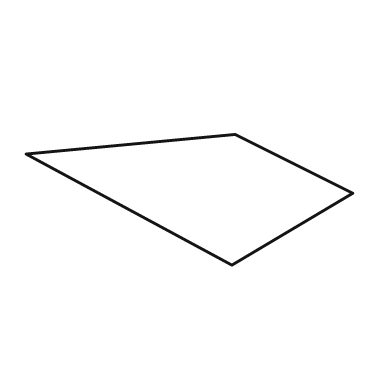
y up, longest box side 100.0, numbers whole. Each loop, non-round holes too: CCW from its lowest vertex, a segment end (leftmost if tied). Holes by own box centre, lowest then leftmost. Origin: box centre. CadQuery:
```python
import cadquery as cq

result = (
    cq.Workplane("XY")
    .moveTo(13.0, -20.0)
    .lineTo(50.0, 2.0)
    .lineTo(14.0, 20.0)
    .lineTo(-50.0, 14.0)
    .close()
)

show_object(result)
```